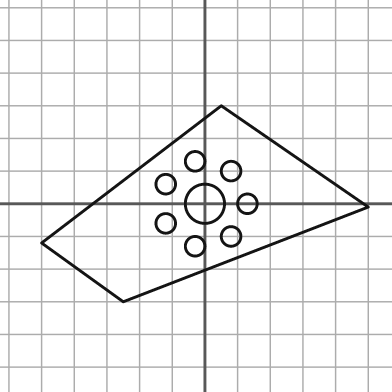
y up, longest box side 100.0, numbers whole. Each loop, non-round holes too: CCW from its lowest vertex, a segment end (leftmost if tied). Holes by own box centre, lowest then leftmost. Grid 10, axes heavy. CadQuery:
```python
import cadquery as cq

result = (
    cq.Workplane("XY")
    .moveTo(-25.0, -30.0)
    .lineTo(50.0, -1.0)
    .lineTo(5.0, 30.0)
    .lineTo(-50.0, -12.0)
    .close()
    .moveTo(-3.0, -13.0)
    .circle(3.0)
    .moveTo(8.0, -10.0)
    .circle(3.0)
    .moveTo(-12.0, -6.0)
    .circle(3.0)
    .moveTo(0.0, 0.0)
    .circle(6.0)
    .moveTo(13.0, 0.0)
    .circle(3.0)
    .moveTo(-12.0, 6.0)
    .circle(3.0)
    .moveTo(8.0, 10.0)
    .circle(3.0)
    .moveTo(-3.0, 13.0)
    .circle(3.0)
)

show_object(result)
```